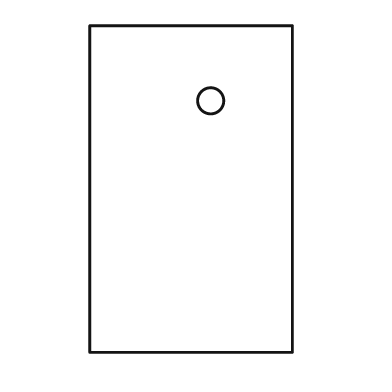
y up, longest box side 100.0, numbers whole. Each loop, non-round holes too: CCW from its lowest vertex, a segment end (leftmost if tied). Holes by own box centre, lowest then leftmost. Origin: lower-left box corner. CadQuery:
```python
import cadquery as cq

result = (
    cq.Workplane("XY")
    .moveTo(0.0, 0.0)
    .lineTo(62.0, 0.0)
    .lineTo(62.0, 100.0)
    .lineTo(0.0, 100.0)
    .close()
    .moveTo(37.0, 77.0)
    .circle(4.0)
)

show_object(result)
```